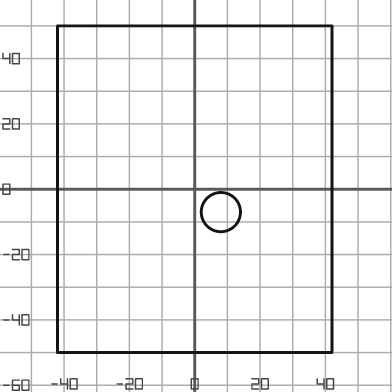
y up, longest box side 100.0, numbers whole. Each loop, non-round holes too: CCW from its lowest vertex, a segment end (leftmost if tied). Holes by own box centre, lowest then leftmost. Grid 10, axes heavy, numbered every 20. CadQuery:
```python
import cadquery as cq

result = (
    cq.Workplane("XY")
    .moveTo(-42.0, -50.0)
    .lineTo(42.0, -50.0)
    .lineTo(42.0, 50.0)
    .lineTo(-42.0, 50.0)
    .close()
    .moveTo(8.0, -7.0)
    .circle(6.0)
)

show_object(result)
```